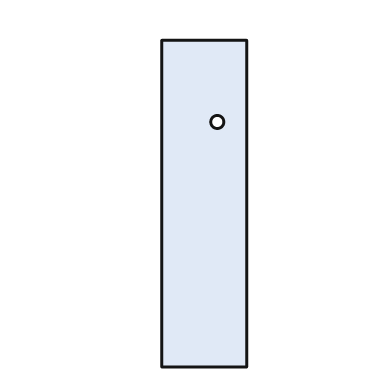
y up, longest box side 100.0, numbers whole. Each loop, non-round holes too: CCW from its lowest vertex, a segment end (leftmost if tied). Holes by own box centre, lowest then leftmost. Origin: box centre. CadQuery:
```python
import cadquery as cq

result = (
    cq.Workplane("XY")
    .moveTo(-13.0, -50.0)
    .lineTo(13.0, -50.0)
    .lineTo(13.0, 50.0)
    .lineTo(-13.0, 50.0)
    .close()
    .moveTo(4.0, 25.0)
    .circle(2.0)
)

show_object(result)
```